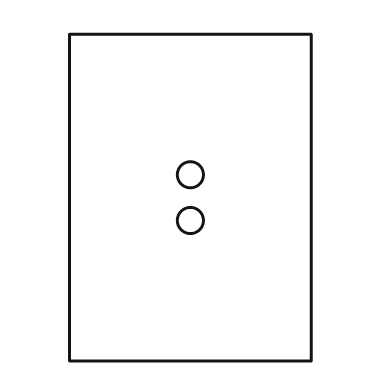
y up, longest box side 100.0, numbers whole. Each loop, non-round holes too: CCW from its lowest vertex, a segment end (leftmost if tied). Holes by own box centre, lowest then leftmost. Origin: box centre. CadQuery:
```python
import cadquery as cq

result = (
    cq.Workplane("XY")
    .moveTo(-37.0, -50.0)
    .lineTo(37.0, -50.0)
    .lineTo(37.0, 50.0)
    .lineTo(-37.0, 50.0)
    .close()
    .moveTo(0.0, -7.0)
    .circle(4.0)
    .moveTo(0.0, 7.0)
    .circle(4.0)
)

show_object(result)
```